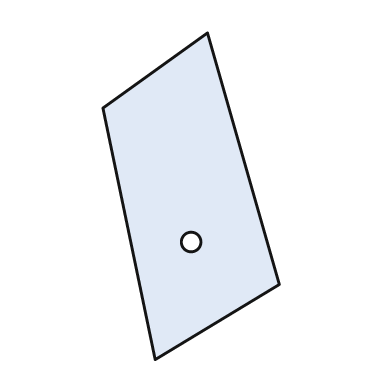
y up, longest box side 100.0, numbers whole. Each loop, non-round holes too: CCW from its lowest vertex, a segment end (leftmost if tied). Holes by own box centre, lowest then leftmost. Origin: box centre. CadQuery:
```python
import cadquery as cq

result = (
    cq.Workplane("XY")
    .moveTo(-11.0, -50.0)
    .lineTo(27.0, -27.0)
    .lineTo(5.0, 50.0)
    .lineTo(-27.0, 27.0)
    .close()
    .moveTo(0.0, -14.0)
    .circle(3.0)
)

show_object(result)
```